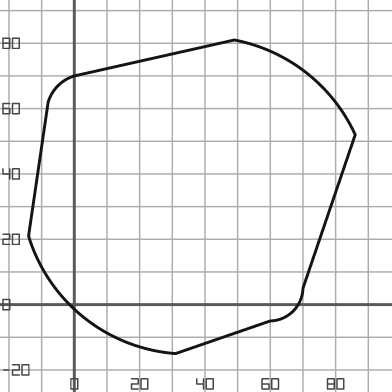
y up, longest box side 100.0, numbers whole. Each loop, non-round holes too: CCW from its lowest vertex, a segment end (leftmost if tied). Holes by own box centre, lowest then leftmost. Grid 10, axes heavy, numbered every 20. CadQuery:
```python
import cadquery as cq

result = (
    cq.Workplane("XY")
    .moveTo(31.0, -15.0)
    .lineTo(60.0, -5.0)
    .threePointArc((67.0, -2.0), (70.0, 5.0))
    .lineTo(86.0, 52.0)
    .threePointArc((71.0, 71.0), (49.0, 81.0))
    .lineTo(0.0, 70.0)
    .threePointArc((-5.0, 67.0), (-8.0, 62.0))
    .lineTo(-14.0, 21.0)
    .threePointArc((3.0, -4.0), (31.0, -15.0))
    .close()
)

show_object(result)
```